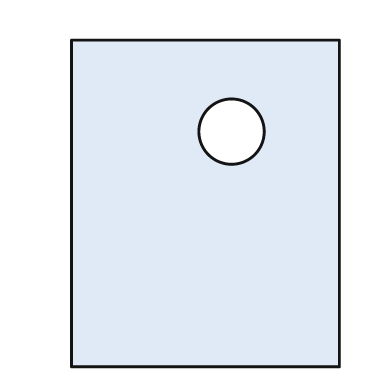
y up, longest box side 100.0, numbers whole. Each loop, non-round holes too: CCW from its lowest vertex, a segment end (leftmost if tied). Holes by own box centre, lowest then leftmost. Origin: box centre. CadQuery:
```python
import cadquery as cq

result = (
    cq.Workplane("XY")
    .moveTo(-41.0, -50.0)
    .lineTo(41.0, -50.0)
    .lineTo(41.0, 50.0)
    .lineTo(-41.0, 50.0)
    .close()
    .moveTo(8.0, 22.0)
    .circle(10.0)
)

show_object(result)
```